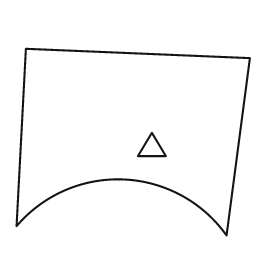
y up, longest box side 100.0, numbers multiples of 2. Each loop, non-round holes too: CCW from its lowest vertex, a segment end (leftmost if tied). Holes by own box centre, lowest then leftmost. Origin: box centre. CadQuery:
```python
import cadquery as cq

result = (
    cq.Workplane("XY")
    .moveTo(40.0, -40.0)
    .lineTo(50.0, 36.0)
    .lineTo(-46.0, 40.0)
    .lineTo(-50.0, -36.0)
    .threePointArc((-4.0, -16.0), (40.0, -40.0))
    .close()
    .moveTo(2.0, -6.0)
    .lineTo(14.0, -6.0)
    .lineTo(8.0, 4.0)
    .close()
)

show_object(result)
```